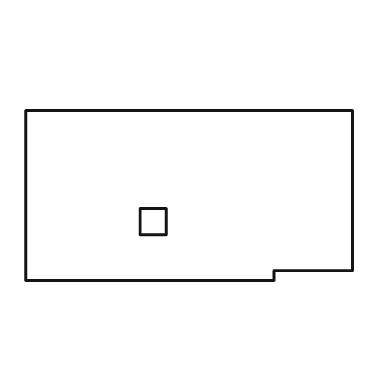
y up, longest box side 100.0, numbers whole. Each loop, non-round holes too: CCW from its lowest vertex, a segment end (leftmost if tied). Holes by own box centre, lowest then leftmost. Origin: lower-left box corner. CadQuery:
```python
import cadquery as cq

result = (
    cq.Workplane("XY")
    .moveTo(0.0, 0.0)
    .lineTo(76.0, 0.0)
    .lineTo(76.0, 3.0)
    .lineTo(100.0, 3.0)
    .lineTo(100.0, 52.0)
    .lineTo(0.0, 52.0)
    .close()
    .moveTo(35.0, 14.0)
    .lineTo(43.0, 14.0)
    .lineTo(43.0, 22.0)
    .lineTo(35.0, 22.0)
    .close()
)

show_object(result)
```